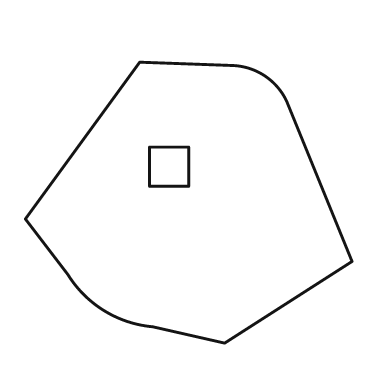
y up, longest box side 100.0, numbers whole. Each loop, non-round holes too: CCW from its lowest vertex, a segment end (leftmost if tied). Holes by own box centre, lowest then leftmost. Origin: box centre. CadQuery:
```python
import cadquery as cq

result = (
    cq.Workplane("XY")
    .moveTo(11.0, -43.0)
    .lineTo(50.0, -18.0)
    .lineTo(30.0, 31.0)
    .threePointArc((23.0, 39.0), (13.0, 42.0))
    .lineTo(-15.0, 43.0)
    .lineTo(-50.0, -5.0)
    .lineTo(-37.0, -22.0)
    .threePointArc((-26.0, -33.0), (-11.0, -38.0))
    .close()
    .moveTo(-12.0, 5.0)
    .lineTo(0.0, 5.0)
    .lineTo(0.0, 17.0)
    .lineTo(-12.0, 17.0)
    .close()
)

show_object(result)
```